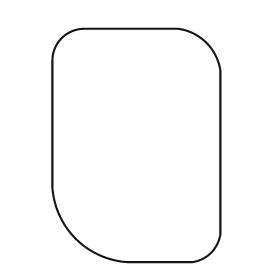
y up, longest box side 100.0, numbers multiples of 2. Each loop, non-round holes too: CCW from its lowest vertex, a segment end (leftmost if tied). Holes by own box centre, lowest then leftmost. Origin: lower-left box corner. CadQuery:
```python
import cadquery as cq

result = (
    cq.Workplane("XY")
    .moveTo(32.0, 0.0)
    .lineTo(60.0, 0.0)
    .threePointArc((68.0, 4.0), (72.0, 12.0))
    .lineTo(72.0, 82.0)
    .threePointArc((66.0, 94.0), (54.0, 100.0))
    .lineTo(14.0, 100.0)
    .threePointArc((4.0, 96.0), (0.0, 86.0))
    .lineTo(0.0, 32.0)
    .threePointArc((10.0, 10.0), (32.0, 0.0))
    .close()
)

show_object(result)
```